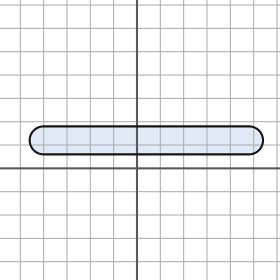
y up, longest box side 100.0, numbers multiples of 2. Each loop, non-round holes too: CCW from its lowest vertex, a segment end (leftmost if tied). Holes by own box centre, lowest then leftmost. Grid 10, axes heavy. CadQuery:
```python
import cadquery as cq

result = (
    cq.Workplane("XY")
    .moveTo(-40.0, 6.0)
    .lineTo(48.0, 6.0)
    .threePointArc((54.0, 12.0), (48.0, 18.0))
    .lineTo(-40.0, 18.0)
    .threePointArc((-46.0, 12.0), (-40.0, 6.0))
    .close()
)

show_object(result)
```